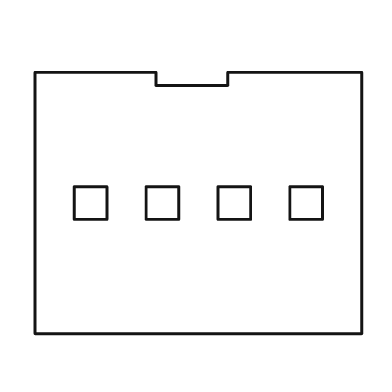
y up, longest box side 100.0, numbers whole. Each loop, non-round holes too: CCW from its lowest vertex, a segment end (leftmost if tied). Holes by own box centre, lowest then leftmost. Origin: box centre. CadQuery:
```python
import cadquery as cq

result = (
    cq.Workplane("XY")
    .moveTo(-50.0, -40.0)
    .lineTo(50.0, -40.0)
    .lineTo(50.0, 40.0)
    .lineTo(9.0, 40.0)
    .lineTo(9.0, 36.0)
    .lineTo(-13.0, 36.0)
    .lineTo(-13.0, 40.0)
    .lineTo(-50.0, 40.0)
    .close()
    .moveTo(-38.0, -5.0)
    .lineTo(-28.0, -5.0)
    .lineTo(-28.0, 5.0)
    .lineTo(-38.0, 5.0)
    .close()
    .moveTo(-16.0, -5.0)
    .lineTo(-6.0, -5.0)
    .lineTo(-6.0, 5.0)
    .lineTo(-16.0, 5.0)
    .close()
    .moveTo(6.0, -5.0)
    .lineTo(16.0, -5.0)
    .lineTo(16.0, 5.0)
    .lineTo(6.0, 5.0)
    .close()
    .moveTo(28.0, -5.0)
    .lineTo(38.0, -5.0)
    .lineTo(38.0, 5.0)
    .lineTo(28.0, 5.0)
    .close()
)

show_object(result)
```